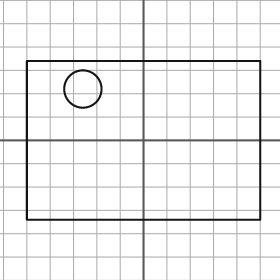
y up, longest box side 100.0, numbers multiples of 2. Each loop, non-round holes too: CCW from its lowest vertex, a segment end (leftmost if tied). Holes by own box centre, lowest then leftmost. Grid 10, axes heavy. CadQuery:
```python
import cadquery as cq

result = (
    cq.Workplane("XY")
    .moveTo(-50.0, -34.0)
    .lineTo(50.0, -34.0)
    .lineTo(50.0, 34.0)
    .lineTo(-50.0, 34.0)
    .close()
    .moveTo(-26.0, 22.0)
    .circle(8.0)
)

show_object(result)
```